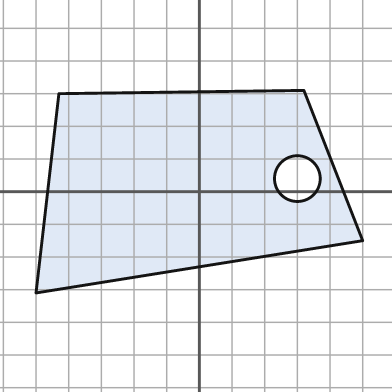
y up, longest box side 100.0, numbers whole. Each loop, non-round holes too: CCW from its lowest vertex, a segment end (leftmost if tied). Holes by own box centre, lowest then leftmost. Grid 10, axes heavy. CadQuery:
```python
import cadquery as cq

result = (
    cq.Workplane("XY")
    .moveTo(-50.0, -31.0)
    .lineTo(50.0, -15.0)
    .lineTo(32.0, 31.0)
    .lineTo(-43.0, 30.0)
    .close()
    .moveTo(30.0, 4.0)
    .circle(7.0)
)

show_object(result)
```